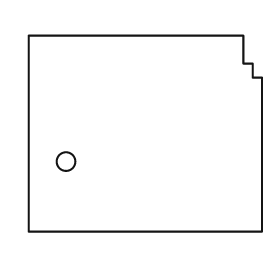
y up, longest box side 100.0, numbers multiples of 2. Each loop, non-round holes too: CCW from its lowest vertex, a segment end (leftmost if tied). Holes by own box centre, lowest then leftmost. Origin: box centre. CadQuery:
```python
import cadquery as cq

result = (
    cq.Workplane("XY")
    .moveTo(-50.0, -42.0)
    .lineTo(50.0, -42.0)
    .lineTo(50.0, 24.0)
    .lineTo(46.0, 24.0)
    .lineTo(46.0, 30.0)
    .lineTo(42.0, 30.0)
    .lineTo(42.0, 42.0)
    .lineTo(-50.0, 42.0)
    .close()
    .moveTo(-34.0, -12.0)
    .circle(4.0)
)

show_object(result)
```